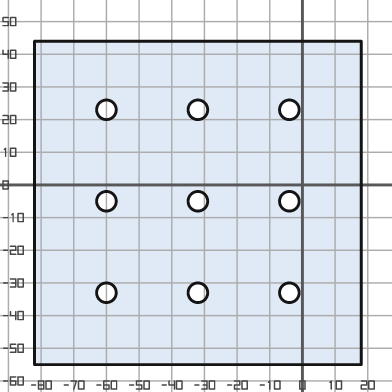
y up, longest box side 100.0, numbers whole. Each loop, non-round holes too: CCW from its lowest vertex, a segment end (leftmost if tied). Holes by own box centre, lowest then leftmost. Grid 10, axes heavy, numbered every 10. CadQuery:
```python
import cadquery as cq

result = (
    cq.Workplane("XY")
    .moveTo(-82.0, -55.0)
    .lineTo(18.0, -55.0)
    .lineTo(18.0, 44.0)
    .lineTo(-82.0, 44.0)
    .close()
    .moveTo(-60.0, -33.0)
    .circle(3.0)
    .moveTo(-32.0, -33.0)
    .circle(3.0)
    .moveTo(-4.0, -33.0)
    .circle(3.0)
    .moveTo(-60.0, -5.0)
    .circle(3.0)
    .moveTo(-32.0, -5.0)
    .circle(3.0)
    .moveTo(-4.0, -5.0)
    .circle(3.0)
    .moveTo(-60.0, 23.0)
    .circle(3.0)
    .moveTo(-32.0, 23.0)
    .circle(3.0)
    .moveTo(-4.0, 23.0)
    .circle(3.0)
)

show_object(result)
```